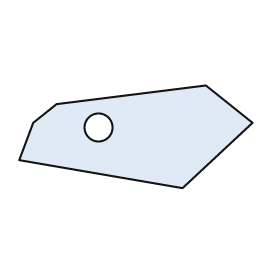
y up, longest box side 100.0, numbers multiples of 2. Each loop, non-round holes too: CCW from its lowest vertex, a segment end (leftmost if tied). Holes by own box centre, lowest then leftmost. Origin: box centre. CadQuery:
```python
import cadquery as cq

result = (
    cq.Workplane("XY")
    .moveTo(20.0, -22.0)
    .lineTo(50.0, 6.0)
    .lineTo(30.0, 22.0)
    .lineTo(-34.0, 14.0)
    .lineTo(-44.0, 6.0)
    .lineTo(-50.0, -10.0)
    .close()
    .moveTo(-16.0, 4.0)
    .circle(6.0)
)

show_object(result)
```